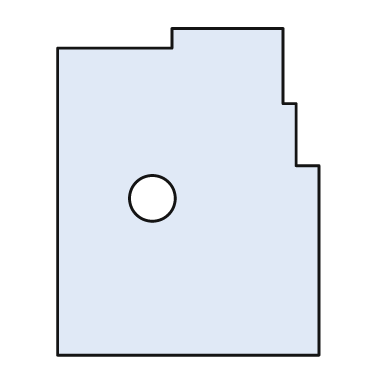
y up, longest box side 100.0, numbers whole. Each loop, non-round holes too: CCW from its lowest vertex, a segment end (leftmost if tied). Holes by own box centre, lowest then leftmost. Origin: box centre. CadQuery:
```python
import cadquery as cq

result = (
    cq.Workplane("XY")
    .moveTo(-40.0, -50.0)
    .lineTo(40.0, -50.0)
    .lineTo(40.0, 8.0)
    .lineTo(33.0, 8.0)
    .lineTo(33.0, 27.0)
    .lineTo(29.0, 27.0)
    .lineTo(29.0, 50.0)
    .lineTo(-5.0, 50.0)
    .lineTo(-5.0, 44.0)
    .lineTo(-40.0, 44.0)
    .close()
    .moveTo(-11.0, -2.0)
    .circle(7.0)
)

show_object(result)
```